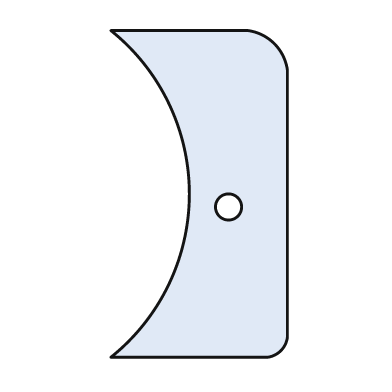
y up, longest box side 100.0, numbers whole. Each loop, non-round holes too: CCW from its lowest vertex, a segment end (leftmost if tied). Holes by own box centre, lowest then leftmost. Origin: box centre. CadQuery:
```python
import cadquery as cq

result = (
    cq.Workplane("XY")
    .moveTo(-27.0, -50.0)
    .lineTo(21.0, -50.0)
    .threePointArc((25.0, -48.0), (27.0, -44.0))
    .lineTo(27.0, 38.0)
    .threePointArc((23.0, 46.0), (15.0, 50.0))
    .lineTo(-27.0, 50.0)
    .threePointArc((-3.0, 0.0), (-27.0, -50.0))
    .close()
    .moveTo(9.0, -4.0)
    .circle(4.0)
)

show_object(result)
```